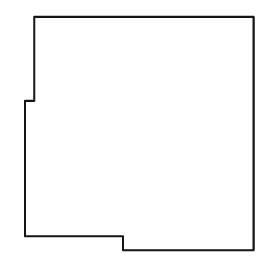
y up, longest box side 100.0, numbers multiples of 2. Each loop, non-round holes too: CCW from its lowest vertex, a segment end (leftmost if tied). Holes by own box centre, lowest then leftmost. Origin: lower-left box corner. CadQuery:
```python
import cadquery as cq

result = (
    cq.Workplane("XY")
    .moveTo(42.0, 0.0)
    .lineTo(98.0, 0.0)
    .lineTo(98.0, 100.0)
    .lineTo(4.0, 100.0)
    .lineTo(4.0, 64.0)
    .lineTo(0.0, 64.0)
    .lineTo(0.0, 6.0)
    .lineTo(42.0, 6.0)
    .close()
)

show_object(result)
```